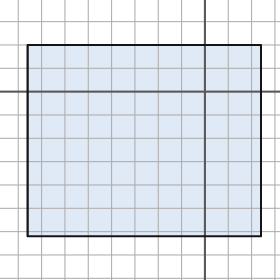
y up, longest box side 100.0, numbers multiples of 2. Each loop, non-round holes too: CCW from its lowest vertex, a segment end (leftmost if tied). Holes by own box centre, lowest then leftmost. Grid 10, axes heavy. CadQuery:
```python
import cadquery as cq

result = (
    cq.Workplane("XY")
    .moveTo(-76.0, -62.0)
    .lineTo(24.0, -62.0)
    .lineTo(24.0, 20.0)
    .lineTo(-76.0, 20.0)
    .close()
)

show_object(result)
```